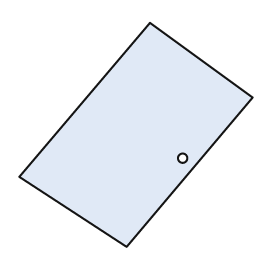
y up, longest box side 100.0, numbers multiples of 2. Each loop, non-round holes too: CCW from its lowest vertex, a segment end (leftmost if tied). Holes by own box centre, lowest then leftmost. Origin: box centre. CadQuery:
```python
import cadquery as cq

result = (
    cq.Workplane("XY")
    .moveTo(-4.0, -48.0)
    .lineTo(50.0, 16.0)
    .lineTo(6.0, 48.0)
    .lineTo(-50.0, -18.0)
    .close()
    .moveTo(20.0, -10.0)
    .circle(2.0)
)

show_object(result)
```